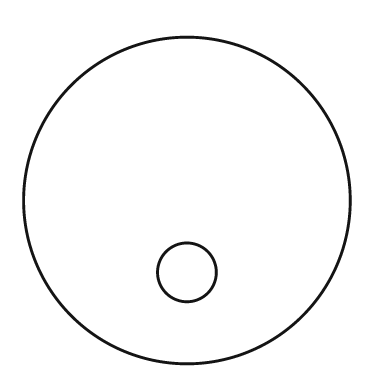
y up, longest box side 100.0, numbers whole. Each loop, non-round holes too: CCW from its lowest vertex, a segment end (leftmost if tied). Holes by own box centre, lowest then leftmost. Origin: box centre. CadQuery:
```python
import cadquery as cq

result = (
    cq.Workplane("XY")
    .moveTo(0.0, 0.0)
    .circle(50.0)
    .moveTo(0.0, -22.0)
    .circle(9.0)
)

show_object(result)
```